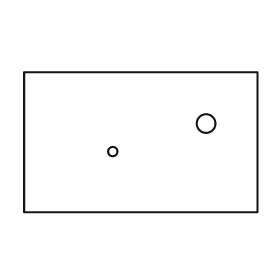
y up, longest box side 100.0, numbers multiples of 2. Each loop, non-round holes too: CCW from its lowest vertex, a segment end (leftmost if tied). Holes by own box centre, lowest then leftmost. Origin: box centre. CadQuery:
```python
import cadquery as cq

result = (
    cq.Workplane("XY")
    .moveTo(-50.0, -30.0)
    .lineTo(50.0, -30.0)
    .lineTo(50.0, 30.0)
    .lineTo(-50.0, 30.0)
    .close()
    .moveTo(-12.0, -4.0)
    .circle(2.0)
    .moveTo(28.0, 8.0)
    .circle(4.0)
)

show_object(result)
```